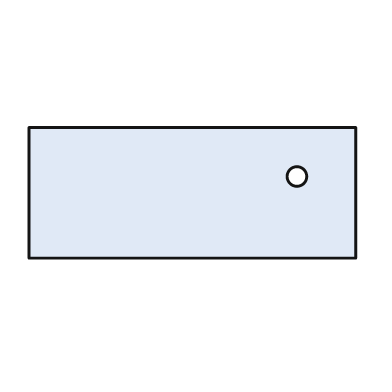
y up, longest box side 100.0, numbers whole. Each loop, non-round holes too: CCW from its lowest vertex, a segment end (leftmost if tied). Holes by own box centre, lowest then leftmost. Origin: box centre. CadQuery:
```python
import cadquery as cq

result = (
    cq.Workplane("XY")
    .moveTo(-50.0, -20.0)
    .lineTo(50.0, -20.0)
    .lineTo(50.0, 20.0)
    .lineTo(-50.0, 20.0)
    .close()
    .moveTo(32.0, 5.0)
    .circle(3.0)
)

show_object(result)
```